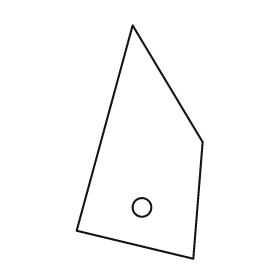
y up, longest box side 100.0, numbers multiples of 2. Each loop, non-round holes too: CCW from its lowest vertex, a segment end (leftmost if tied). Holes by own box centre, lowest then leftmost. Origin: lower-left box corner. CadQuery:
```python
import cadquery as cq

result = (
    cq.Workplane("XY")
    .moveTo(50.0, 0.0)
    .lineTo(54.0, 50.0)
    .lineTo(24.0, 100.0)
    .lineTo(0.0, 12.0)
    .close()
    .moveTo(28.0, 22.0)
    .circle(4.0)
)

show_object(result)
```